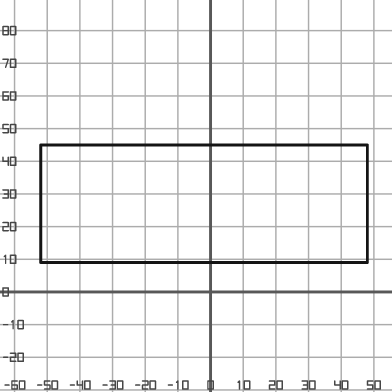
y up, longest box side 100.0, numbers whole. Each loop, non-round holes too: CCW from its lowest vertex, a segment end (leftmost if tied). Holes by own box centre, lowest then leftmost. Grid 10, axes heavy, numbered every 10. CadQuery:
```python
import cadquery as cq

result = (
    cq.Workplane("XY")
    .moveTo(-52.0, 9.0)
    .lineTo(48.0, 9.0)
    .lineTo(48.0, 45.0)
    .lineTo(-52.0, 45.0)
    .close()
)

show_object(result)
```